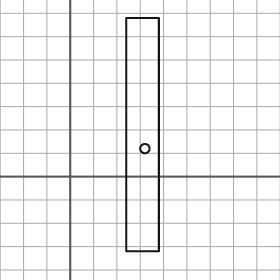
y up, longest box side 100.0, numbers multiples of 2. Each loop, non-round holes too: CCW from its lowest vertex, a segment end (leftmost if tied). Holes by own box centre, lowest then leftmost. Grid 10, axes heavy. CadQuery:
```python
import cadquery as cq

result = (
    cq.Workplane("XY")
    .moveTo(24.0, -32.0)
    .lineTo(38.0, -32.0)
    .lineTo(38.0, 68.0)
    .lineTo(24.0, 68.0)
    .close()
    .moveTo(32.0, 12.0)
    .circle(2.0)
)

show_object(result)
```